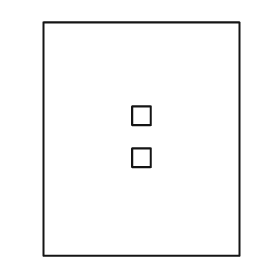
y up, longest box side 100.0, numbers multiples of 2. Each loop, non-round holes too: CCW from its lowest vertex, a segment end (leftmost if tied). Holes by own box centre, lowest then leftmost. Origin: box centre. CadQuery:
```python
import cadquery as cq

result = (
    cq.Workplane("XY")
    .moveTo(-42.0, -50.0)
    .lineTo(42.0, -50.0)
    .lineTo(42.0, 50.0)
    .lineTo(-42.0, 50.0)
    .close()
    .moveTo(-4.0, -12.0)
    .lineTo(4.0, -12.0)
    .lineTo(4.0, -4.0)
    .lineTo(-4.0, -4.0)
    .close()
    .moveTo(-4.0, 6.0)
    .lineTo(4.0, 6.0)
    .lineTo(4.0, 14.0)
    .lineTo(-4.0, 14.0)
    .close()
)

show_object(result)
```